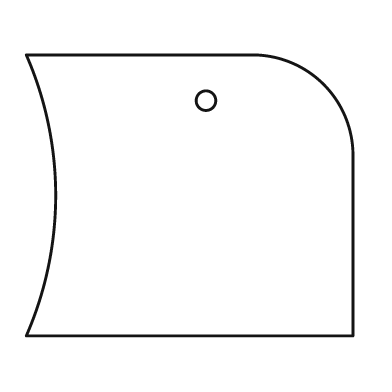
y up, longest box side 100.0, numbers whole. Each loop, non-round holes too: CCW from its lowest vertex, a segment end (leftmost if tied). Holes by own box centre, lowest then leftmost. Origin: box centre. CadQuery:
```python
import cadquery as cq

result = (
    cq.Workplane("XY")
    .moveTo(-50.0, -43.0)
    .lineTo(50.0, -43.0)
    .lineTo(50.0, 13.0)
    .threePointArc((41.0, 34.0), (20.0, 43.0))
    .lineTo(-50.0, 43.0)
    .threePointArc((-41.0, 0.0), (-50.0, -43.0))
    .close()
    .moveTo(5.0, 29.0)
    .circle(3.0)
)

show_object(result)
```